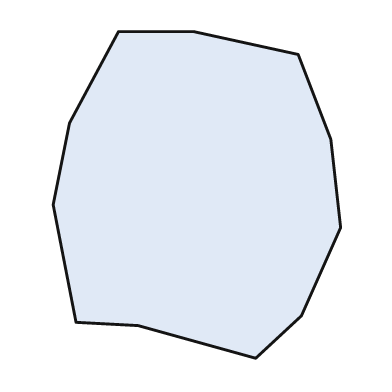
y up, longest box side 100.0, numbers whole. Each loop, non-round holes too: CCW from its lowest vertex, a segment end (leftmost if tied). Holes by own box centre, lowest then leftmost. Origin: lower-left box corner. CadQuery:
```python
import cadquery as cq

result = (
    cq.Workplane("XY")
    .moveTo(62.0, 0.0)
    .lineTo(76.0, 13.0)
    .lineTo(88.0, 40.0)
    .lineTo(85.0, 67.0)
    .lineTo(75.0, 93.0)
    .lineTo(43.0, 100.0)
    .lineTo(20.0, 100.0)
    .lineTo(5.0, 72.0)
    .lineTo(0.0, 47.0)
    .lineTo(7.0, 11.0)
    .lineTo(26.0, 10.0)
    .close()
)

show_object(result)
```